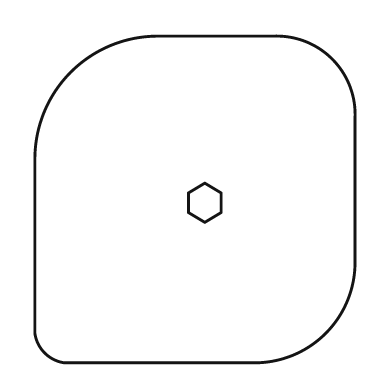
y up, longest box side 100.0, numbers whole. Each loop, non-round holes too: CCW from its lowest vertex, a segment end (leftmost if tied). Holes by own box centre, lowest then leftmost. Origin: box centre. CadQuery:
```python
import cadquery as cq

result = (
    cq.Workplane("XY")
    .moveTo(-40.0, -50.0)
    .lineTo(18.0, -50.0)
    .threePointArc((40.0, -41.0), (49.0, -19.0))
    .lineTo(49.0, 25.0)
    .threePointArc((42.0, 43.0), (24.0, 50.0))
    .lineTo(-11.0, 50.0)
    .threePointArc((-38.0, 39.0), (-49.0, 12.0))
    .lineTo(-49.0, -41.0)
    .threePointArc((-46.0, -47.0), (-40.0, -50.0))
    .close()
    .moveTo(3.0, -7.0)
    .lineTo(8.0, -4.0)
    .lineTo(8.0, 2.0)
    .lineTo(3.0, 5.0)
    .lineTo(-2.0, 2.0)
    .lineTo(-2.0, -4.0)
    .close()
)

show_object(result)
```